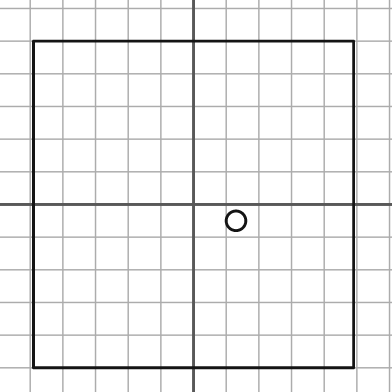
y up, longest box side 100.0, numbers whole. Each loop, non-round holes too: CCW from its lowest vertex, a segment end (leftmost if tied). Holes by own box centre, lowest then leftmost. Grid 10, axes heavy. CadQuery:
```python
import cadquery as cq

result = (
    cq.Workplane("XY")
    .moveTo(-49.0, -50.0)
    .lineTo(49.0, -50.0)
    .lineTo(49.0, 50.0)
    .lineTo(-49.0, 50.0)
    .close()
    .moveTo(13.0, -5.0)
    .circle(3.0)
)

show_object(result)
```